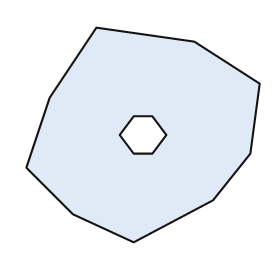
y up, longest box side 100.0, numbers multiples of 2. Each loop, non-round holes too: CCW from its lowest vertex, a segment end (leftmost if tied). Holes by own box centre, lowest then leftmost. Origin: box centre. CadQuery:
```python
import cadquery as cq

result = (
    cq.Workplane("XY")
    .moveTo(-4.0, -46.0)
    .lineTo(30.0, -28.0)
    .lineTo(46.0, -8.0)
    .lineTo(50.0, 22.0)
    .lineTo(22.0, 40.0)
    .lineTo(-20.0, 46.0)
    .lineTo(-40.0, 16.0)
    .lineTo(-50.0, -14.0)
    .lineTo(-30.0, -34.0)
    .close()
    .moveTo(-4.0, -8.0)
    .lineTo(4.0, -8.0)
    .lineTo(10.0, 0.0)
    .lineTo(4.0, 8.0)
    .lineTo(-4.0, 8.0)
    .lineTo(-10.0, 0.0)
    .close()
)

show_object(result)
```